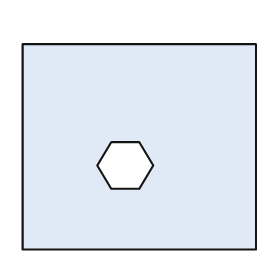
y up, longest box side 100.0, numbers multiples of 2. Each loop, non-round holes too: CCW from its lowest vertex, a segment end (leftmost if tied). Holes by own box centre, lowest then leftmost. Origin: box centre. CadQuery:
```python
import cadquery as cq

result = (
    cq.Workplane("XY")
    .moveTo(-50.0, -44.0)
    .lineTo(50.0, -44.0)
    .lineTo(50.0, 44.0)
    .lineTo(-50.0, 44.0)
    .close()
    .moveTo(-12.0, -18.0)
    .lineTo(0.0, -18.0)
    .lineTo(6.0, -8.0)
    .lineTo(0.0, 2.0)
    .lineTo(-12.0, 2.0)
    .lineTo(-18.0, -8.0)
    .close()
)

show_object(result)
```